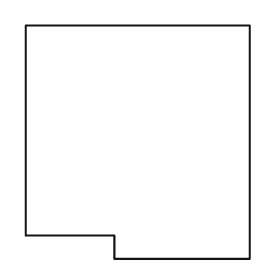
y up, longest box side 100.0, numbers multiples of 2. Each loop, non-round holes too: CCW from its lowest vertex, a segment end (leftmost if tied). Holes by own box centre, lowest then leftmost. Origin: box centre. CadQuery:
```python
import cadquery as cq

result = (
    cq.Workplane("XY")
    .moveTo(-10.0, -50.0)
    .lineTo(48.0, -50.0)
    .lineTo(48.0, 50.0)
    .lineTo(-48.0, 50.0)
    .lineTo(-48.0, -40.0)
    .lineTo(-10.0, -40.0)
    .close()
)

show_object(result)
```